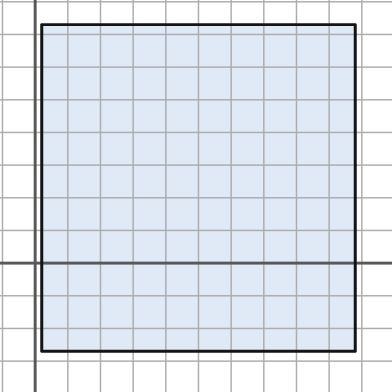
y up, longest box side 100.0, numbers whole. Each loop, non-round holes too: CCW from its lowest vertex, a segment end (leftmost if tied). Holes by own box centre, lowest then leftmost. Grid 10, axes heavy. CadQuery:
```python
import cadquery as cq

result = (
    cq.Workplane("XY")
    .moveTo(2.0, -27.0)
    .lineTo(98.0, -27.0)
    .lineTo(98.0, 73.0)
    .lineTo(2.0, 73.0)
    .close()
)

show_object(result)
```